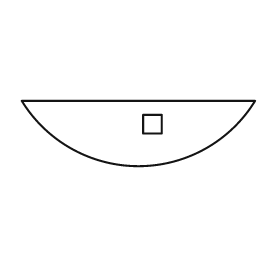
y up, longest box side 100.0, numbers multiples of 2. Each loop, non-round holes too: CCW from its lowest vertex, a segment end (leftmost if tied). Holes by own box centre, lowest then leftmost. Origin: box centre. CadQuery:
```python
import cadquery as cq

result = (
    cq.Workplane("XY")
    .moveTo(-50.0, 14.0)
    .threePointArc((0.0, -14.0), (50.0, 14.0))
    .close()
    .moveTo(2.0, 0.0)
    .lineTo(10.0, 0.0)
    .lineTo(10.0, 8.0)
    .lineTo(2.0, 8.0)
    .close()
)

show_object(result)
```